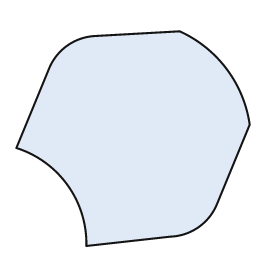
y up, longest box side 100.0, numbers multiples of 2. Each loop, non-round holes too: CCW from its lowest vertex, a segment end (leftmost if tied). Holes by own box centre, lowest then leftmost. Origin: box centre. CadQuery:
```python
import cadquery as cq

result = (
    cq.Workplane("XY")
    .moveTo(-20.0, -46.0)
    .lineTo(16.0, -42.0)
    .threePointArc((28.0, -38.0), (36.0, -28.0))
    .lineTo(50.0, 6.0)
    .threePointArc((40.0, 30.0), (20.0, 46.0))
    .lineTo(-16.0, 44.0)
    .threePointArc((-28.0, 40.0), (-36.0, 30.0))
    .lineTo(-50.0, -4.0)
    .threePointArc((-28.0, -20.0), (-20.0, -46.0))
    .close()
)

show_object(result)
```